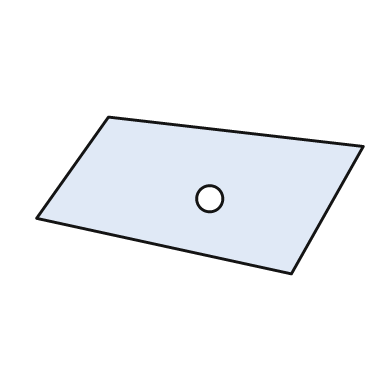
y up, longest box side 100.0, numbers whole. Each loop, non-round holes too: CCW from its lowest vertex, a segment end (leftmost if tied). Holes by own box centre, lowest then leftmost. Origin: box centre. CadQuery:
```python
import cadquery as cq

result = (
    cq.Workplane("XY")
    .moveTo(28.0, -24.0)
    .lineTo(50.0, 15.0)
    .lineTo(-28.0, 24.0)
    .lineTo(-50.0, -7.0)
    .close()
    .moveTo(3.0, -1.0)
    .circle(4.0)
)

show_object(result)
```